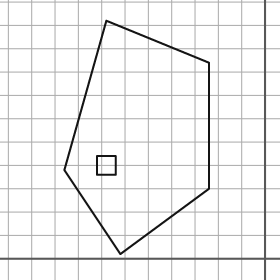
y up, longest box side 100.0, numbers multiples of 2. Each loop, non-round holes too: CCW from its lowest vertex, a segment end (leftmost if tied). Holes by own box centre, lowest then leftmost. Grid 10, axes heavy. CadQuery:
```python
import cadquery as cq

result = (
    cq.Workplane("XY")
    .moveTo(-62.0, 2.0)
    .lineTo(-24.0, 30.0)
    .lineTo(-24.0, 84.0)
    .lineTo(-68.0, 102.0)
    .lineTo(-86.0, 38.0)
    .close()
    .moveTo(-72.0, 36.0)
    .lineTo(-64.0, 36.0)
    .lineTo(-64.0, 44.0)
    .lineTo(-72.0, 44.0)
    .close()
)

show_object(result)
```